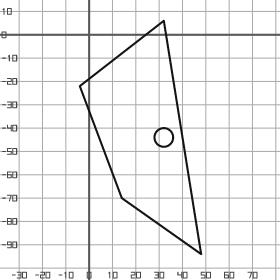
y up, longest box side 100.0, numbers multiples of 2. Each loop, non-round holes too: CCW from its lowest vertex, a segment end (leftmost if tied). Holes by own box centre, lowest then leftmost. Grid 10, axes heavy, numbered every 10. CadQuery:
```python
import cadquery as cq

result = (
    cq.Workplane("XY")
    .moveTo(48.0, -94.0)
    .lineTo(32.0, 6.0)
    .lineTo(-4.0, -22.0)
    .lineTo(14.0, -70.0)
    .close()
    .moveTo(32.0, -44.0)
    .circle(4.0)
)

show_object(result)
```